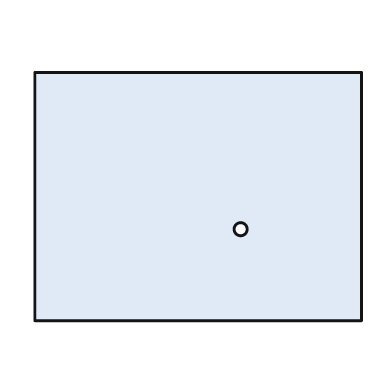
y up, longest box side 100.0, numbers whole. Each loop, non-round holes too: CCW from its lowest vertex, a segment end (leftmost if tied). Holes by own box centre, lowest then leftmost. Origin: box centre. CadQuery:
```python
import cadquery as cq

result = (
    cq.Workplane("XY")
    .moveTo(-50.0, -38.0)
    .lineTo(50.0, -38.0)
    .lineTo(50.0, 38.0)
    .lineTo(-50.0, 38.0)
    .close()
    .moveTo(13.0, -10.0)
    .circle(2.0)
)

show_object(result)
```